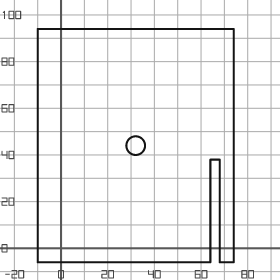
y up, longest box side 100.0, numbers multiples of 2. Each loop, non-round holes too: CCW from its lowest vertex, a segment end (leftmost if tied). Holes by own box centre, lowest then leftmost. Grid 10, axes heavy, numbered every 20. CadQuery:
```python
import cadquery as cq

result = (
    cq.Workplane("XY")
    .moveTo(-10.0, -6.0)
    .lineTo(64.0, -6.0)
    .lineTo(64.0, 38.0)
    .lineTo(68.0, 38.0)
    .lineTo(68.0, -6.0)
    .lineTo(74.0, -6.0)
    .lineTo(74.0, 94.0)
    .lineTo(-10.0, 94.0)
    .close()
    .moveTo(32.0, 44.0)
    .circle(4.0)
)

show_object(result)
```